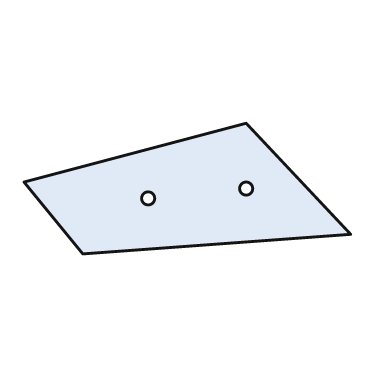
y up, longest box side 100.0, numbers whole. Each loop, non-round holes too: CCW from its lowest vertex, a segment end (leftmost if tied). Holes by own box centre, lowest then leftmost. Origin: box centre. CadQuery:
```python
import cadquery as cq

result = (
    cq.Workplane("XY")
    .moveTo(-32.0, -20.0)
    .lineTo(50.0, -14.0)
    .lineTo(18.0, 20.0)
    .lineTo(-50.0, 2.0)
    .close()
    .moveTo(-12.0, -3.0)
    .circle(2.0)
    .moveTo(18.0, 0.0)
    .circle(2.0)
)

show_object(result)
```